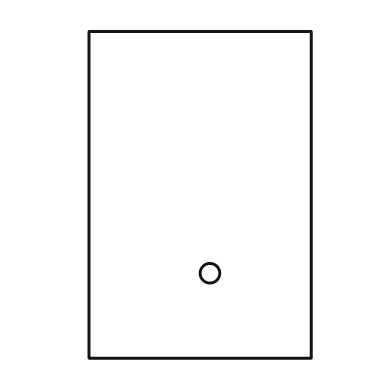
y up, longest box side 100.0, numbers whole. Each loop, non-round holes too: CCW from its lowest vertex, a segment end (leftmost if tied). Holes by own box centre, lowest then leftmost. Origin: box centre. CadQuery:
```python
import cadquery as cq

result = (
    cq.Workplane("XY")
    .moveTo(-34.0, -50.0)
    .lineTo(34.0, -50.0)
    .lineTo(34.0, 50.0)
    .lineTo(-34.0, 50.0)
    .close()
    .moveTo(3.0, -24.0)
    .circle(3.0)
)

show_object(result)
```